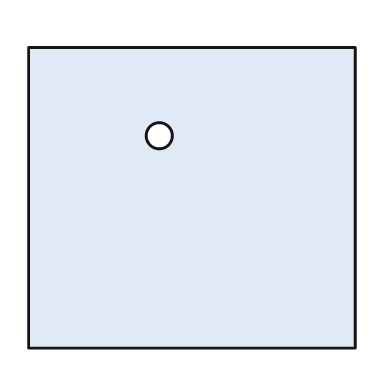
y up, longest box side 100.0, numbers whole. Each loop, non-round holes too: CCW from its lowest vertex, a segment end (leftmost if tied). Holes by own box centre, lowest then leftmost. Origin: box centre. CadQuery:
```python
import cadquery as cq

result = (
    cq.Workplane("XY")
    .moveTo(-50.0, -46.0)
    .lineTo(50.0, -46.0)
    .lineTo(50.0, 46.0)
    .lineTo(-50.0, 46.0)
    .close()
    .moveTo(-10.0, 19.0)
    .circle(4.0)
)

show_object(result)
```